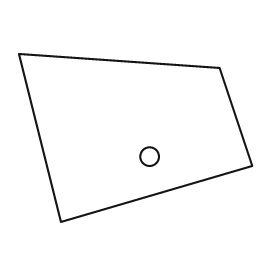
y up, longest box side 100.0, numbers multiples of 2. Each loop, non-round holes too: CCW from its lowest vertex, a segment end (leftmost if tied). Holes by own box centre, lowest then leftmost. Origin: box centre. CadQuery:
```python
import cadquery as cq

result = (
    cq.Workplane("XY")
    .moveTo(-32.0, -36.0)
    .lineTo(50.0, -12.0)
    .lineTo(36.0, 30.0)
    .lineTo(-50.0, 36.0)
    .close()
    .moveTo(6.0, -8.0)
    .circle(4.0)
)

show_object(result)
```